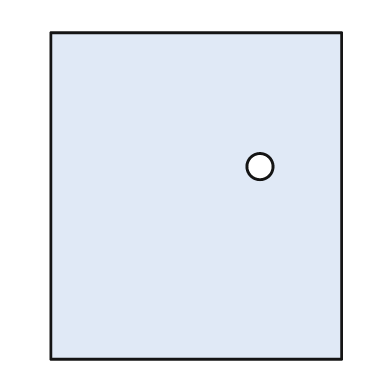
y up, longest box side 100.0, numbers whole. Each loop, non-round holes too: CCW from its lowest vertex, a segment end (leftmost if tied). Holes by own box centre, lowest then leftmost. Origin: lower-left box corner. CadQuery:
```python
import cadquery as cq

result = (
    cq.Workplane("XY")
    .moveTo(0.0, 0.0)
    .lineTo(89.0, 0.0)
    .lineTo(89.0, 100.0)
    .lineTo(0.0, 100.0)
    .close()
    .moveTo(64.0, 59.0)
    .circle(4.0)
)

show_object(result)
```